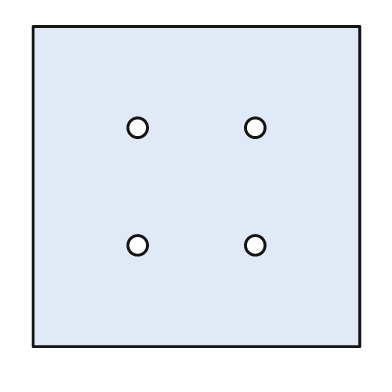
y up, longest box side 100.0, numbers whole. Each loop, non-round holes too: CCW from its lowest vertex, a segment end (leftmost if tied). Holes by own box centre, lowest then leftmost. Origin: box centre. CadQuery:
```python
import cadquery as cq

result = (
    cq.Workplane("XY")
    .moveTo(-50.0, -49.0)
    .lineTo(50.0, -49.0)
    .lineTo(50.0, 49.0)
    .lineTo(-50.0, 49.0)
    .close()
    .moveTo(-18.0, -18.0)
    .circle(3.0)
    .moveTo(18.0, -18.0)
    .circle(3.0)
    .moveTo(-18.0, 18.0)
    .circle(3.0)
    .moveTo(18.0, 18.0)
    .circle(3.0)
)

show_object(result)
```